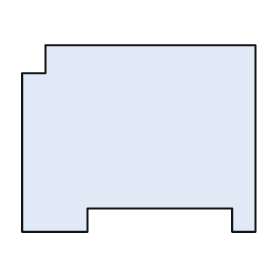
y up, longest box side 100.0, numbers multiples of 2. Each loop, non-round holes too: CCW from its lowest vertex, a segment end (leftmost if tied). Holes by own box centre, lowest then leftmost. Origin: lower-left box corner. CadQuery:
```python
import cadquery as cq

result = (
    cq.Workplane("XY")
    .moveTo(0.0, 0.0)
    .lineTo(28.0, 0.0)
    .lineTo(28.0, 10.0)
    .lineTo(90.0, 10.0)
    .lineTo(90.0, 0.0)
    .lineTo(100.0, 0.0)
    .lineTo(100.0, 80.0)
    .lineTo(10.0, 80.0)
    .lineTo(10.0, 68.0)
    .lineTo(0.0, 68.0)
    .close()
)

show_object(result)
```